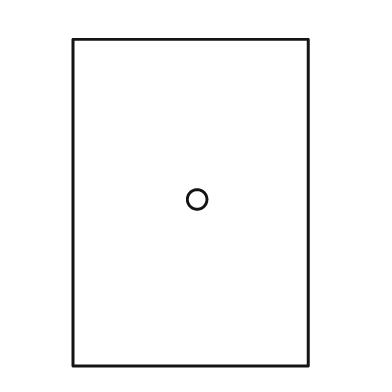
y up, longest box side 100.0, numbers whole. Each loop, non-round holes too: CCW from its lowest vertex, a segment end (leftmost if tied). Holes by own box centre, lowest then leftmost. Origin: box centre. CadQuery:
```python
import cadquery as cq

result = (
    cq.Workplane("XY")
    .moveTo(-36.0, -50.0)
    .lineTo(36.0, -50.0)
    .lineTo(36.0, 50.0)
    .lineTo(-36.0, 50.0)
    .close()
    .moveTo(2.0, 1.0)
    .circle(3.0)
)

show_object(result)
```